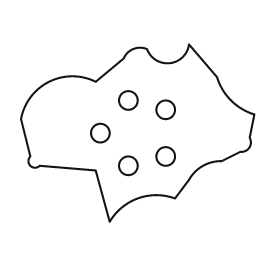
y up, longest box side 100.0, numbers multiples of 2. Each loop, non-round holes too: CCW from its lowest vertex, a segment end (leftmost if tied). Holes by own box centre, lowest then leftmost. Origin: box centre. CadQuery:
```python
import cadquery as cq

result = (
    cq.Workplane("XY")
    .moveTo(-12.0, -38.0)
    .threePointArc((0.0, -28.0), (16.0, -28.0))
    .lineTo(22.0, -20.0)
    .threePointArc((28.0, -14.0), (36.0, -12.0))
    .lineTo(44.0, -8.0)
    .threePointArc((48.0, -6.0), (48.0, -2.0))
    .lineTo(50.0, 8.0)
    .threePointArc((40.0, 14.0), (34.0, 24.0))
    .lineTo(22.0, 38.0)
    .threePointArc((14.0, 30.0), (4.0, 36.0))
    .threePointArc((-2.0, 36.0), (-6.0, 32.0))
    .lineTo(-18.0, 22.0)
    .threePointArc((-38.0, 22.0), (-50.0, 6.0))
    .lineTo(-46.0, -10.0)
    .threePointArc((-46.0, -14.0), (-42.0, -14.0))
    .lineTo(-18.0, -16.0)
    .close()
    .moveTo(-4.0, -14.0)
    .circle(4.0)
    .moveTo(12.0, -10.0)
    .circle(4.0)
    .moveTo(-16.0, 0.0)
    .circle(4.0)
    .moveTo(12.0, 10.0)
    .circle(4.0)
    .moveTo(-4.0, 14.0)
    .circle(4.0)
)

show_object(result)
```